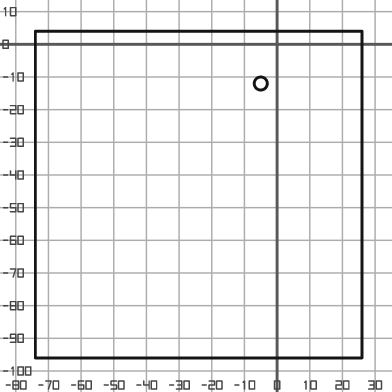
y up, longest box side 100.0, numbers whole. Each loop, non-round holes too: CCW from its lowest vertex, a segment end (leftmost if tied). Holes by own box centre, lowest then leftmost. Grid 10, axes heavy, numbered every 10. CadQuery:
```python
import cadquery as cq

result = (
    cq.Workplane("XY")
    .moveTo(-74.0, -96.0)
    .lineTo(26.0, -96.0)
    .lineTo(26.0, 4.0)
    .lineTo(-74.0, 4.0)
    .close()
    .moveTo(-5.0, -12.0)
    .circle(2.0)
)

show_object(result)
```